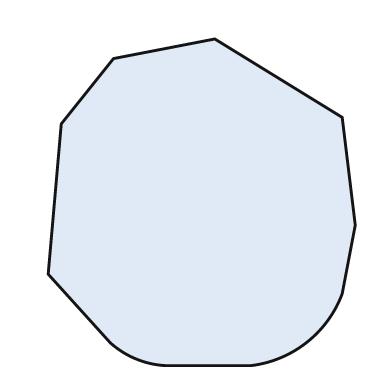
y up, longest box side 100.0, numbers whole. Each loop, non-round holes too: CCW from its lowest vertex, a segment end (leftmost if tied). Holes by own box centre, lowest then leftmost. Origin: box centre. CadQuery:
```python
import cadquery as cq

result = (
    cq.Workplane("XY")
    .moveTo(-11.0, -50.0)
    .lineTo(15.0, -50.0)
    .threePointArc((32.0, -43.0), (43.0, -28.0))
    .lineTo(47.0, -7.0)
    .lineTo(43.0, 26.0)
    .lineTo(4.0, 50.0)
    .lineTo(-27.0, 44.0)
    .lineTo(-43.0, 24.0)
    .lineTo(-47.0, -22.0)
    .lineTo(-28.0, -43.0)
    .threePointArc((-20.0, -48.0), (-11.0, -50.0))
    .close()
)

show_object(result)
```